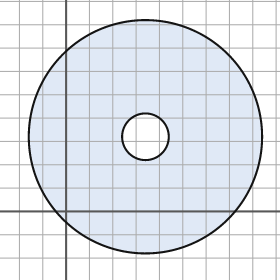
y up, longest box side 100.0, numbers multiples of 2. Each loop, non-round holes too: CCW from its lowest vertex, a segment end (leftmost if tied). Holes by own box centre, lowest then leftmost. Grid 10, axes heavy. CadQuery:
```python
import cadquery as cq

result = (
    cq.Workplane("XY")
    .moveTo(34.0, 32.0)
    .circle(50.0)
    .moveTo(34.0, 32.0)
    .circle(10.0)
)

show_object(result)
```